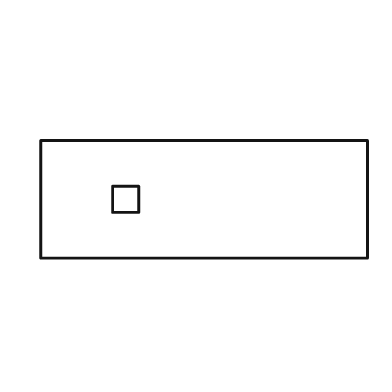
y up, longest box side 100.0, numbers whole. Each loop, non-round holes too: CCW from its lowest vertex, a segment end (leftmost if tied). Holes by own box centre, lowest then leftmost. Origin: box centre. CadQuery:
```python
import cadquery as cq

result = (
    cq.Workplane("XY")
    .moveTo(-50.0, -18.0)
    .lineTo(50.0, -18.0)
    .lineTo(50.0, 18.0)
    .lineTo(-50.0, 18.0)
    .close()
    .moveTo(-28.0, -4.0)
    .lineTo(-20.0, -4.0)
    .lineTo(-20.0, 4.0)
    .lineTo(-28.0, 4.0)
    .close()
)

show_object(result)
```